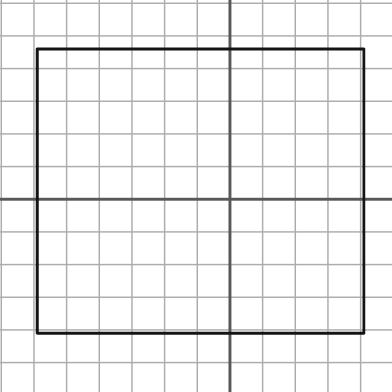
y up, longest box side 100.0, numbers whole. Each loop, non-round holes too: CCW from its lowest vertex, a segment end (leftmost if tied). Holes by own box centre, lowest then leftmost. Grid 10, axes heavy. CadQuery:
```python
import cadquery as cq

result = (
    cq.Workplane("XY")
    .moveTo(-59.0, -41.0)
    .lineTo(41.0, -41.0)
    .lineTo(41.0, 46.0)
    .lineTo(-59.0, 46.0)
    .close()
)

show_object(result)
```